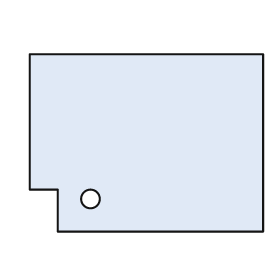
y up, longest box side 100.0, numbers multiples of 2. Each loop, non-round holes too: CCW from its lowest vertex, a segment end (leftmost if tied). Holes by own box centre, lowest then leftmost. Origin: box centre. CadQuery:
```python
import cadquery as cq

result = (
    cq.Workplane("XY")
    .moveTo(-38.0, -38.0)
    .lineTo(50.0, -38.0)
    .lineTo(50.0, 38.0)
    .lineTo(-50.0, 38.0)
    .lineTo(-50.0, -20.0)
    .lineTo(-38.0, -20.0)
    .close()
    .moveTo(-24.0, -24.0)
    .circle(4.0)
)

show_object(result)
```